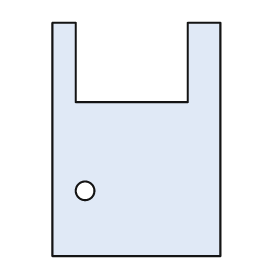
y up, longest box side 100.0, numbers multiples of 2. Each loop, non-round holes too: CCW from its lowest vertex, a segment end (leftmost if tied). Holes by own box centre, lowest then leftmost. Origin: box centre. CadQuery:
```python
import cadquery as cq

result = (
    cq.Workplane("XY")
    .moveTo(-36.0, -50.0)
    .lineTo(36.0, -50.0)
    .lineTo(36.0, 50.0)
    .lineTo(22.0, 50.0)
    .lineTo(22.0, 16.0)
    .lineTo(-26.0, 16.0)
    .lineTo(-26.0, 50.0)
    .lineTo(-36.0, 50.0)
    .close()
    .moveTo(-22.0, -22.0)
    .circle(4.0)
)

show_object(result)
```